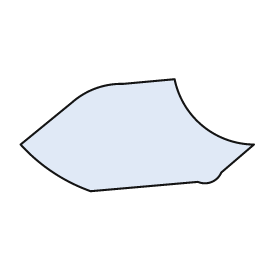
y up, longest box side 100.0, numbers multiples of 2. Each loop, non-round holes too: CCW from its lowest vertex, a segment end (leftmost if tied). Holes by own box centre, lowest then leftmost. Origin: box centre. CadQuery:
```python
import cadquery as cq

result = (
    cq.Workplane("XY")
    .moveTo(-20.0, -24.0)
    .lineTo(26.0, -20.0)
    .threePointArc((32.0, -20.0), (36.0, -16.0))
    .lineTo(50.0, -4.0)
    .threePointArc((28.0, 4.0), (16.0, 24.0))
    .lineTo(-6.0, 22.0)
    .threePointArc((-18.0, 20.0), (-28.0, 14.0))
    .lineTo(-50.0, -4.0)
    .threePointArc((-36.0, -16.0), (-20.0, -24.0))
    .close()
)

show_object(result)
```